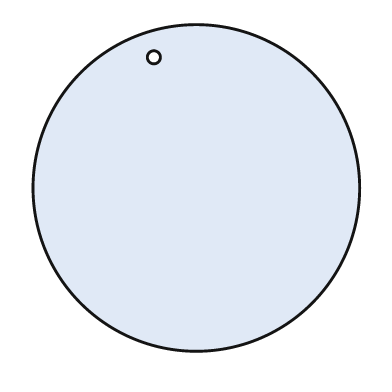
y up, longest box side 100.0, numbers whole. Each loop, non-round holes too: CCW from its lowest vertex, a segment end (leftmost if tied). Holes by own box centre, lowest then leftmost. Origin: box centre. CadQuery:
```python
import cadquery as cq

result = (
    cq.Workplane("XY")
    .moveTo(0.0, 0.0)
    .circle(50.0)
    .moveTo(-13.0, 40.0)
    .circle(2.0)
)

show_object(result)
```